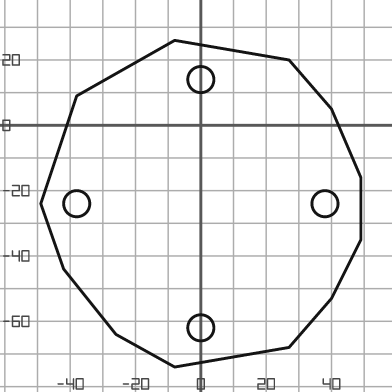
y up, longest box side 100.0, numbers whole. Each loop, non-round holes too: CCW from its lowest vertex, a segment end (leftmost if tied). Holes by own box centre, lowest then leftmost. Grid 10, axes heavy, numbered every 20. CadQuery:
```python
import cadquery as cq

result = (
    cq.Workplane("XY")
    .moveTo(-8.0, -74.0)
    .lineTo(27.0, -68.0)
    .lineTo(40.0, -53.0)
    .lineTo(49.0, -35.0)
    .lineTo(49.0, -16.0)
    .lineTo(40.0, 5.0)
    .lineTo(27.0, 20.0)
    .lineTo(-8.0, 26.0)
    .lineTo(-38.0, 9.0)
    .lineTo(-49.0, -24.0)
    .lineTo(-42.0, -44.0)
    .lineTo(-26.0, -64.0)
    .close()
    .moveTo(0.0, -62.0)
    .circle(4.0)
    .moveTo(-38.0, -24.0)
    .circle(4.0)
    .moveTo(38.0, -24.0)
    .circle(4.0)
    .moveTo(0.0, 14.0)
    .circle(4.0)
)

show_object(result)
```